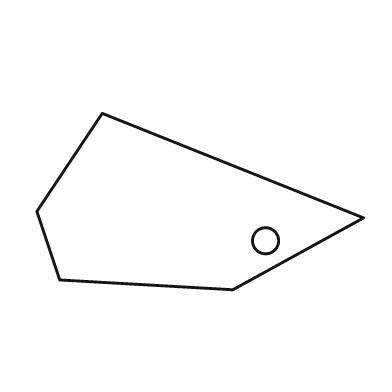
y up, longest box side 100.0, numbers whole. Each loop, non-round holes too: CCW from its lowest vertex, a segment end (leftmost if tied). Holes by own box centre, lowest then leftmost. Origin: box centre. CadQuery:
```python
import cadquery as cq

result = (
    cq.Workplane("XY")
    .moveTo(10.0, -27.0)
    .lineTo(50.0, -5.0)
    .lineTo(-30.0, 27.0)
    .lineTo(-50.0, -3.0)
    .lineTo(-43.0, -24.0)
    .close()
    .moveTo(20.0, -12.0)
    .circle(4.0)
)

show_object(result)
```